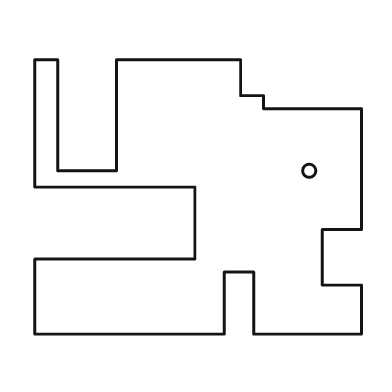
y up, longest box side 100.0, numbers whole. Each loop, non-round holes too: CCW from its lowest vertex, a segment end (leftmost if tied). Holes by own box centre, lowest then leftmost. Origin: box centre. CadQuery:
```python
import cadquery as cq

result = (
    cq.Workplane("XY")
    .moveTo(-50.0, -42.0)
    .lineTo(8.0, -42.0)
    .lineTo(8.0, -23.0)
    .lineTo(17.0, -23.0)
    .lineTo(17.0, -42.0)
    .lineTo(50.0, -42.0)
    .lineTo(50.0, -27.0)
    .lineTo(38.0, -27.0)
    .lineTo(38.0, -10.0)
    .lineTo(50.0, -10.0)
    .lineTo(50.0, 27.0)
    .lineTo(20.0, 27.0)
    .lineTo(20.0, 31.0)
    .lineTo(13.0, 31.0)
    .lineTo(13.0, 42.0)
    .lineTo(-25.0, 42.0)
    .lineTo(-25.0, 8.0)
    .lineTo(-43.0, 8.0)
    .lineTo(-43.0, 42.0)
    .lineTo(-50.0, 42.0)
    .lineTo(-50.0, 3.0)
    .lineTo(-1.0, 3.0)
    .lineTo(-1.0, -19.0)
    .lineTo(-50.0, -19.0)
    .close()
    .moveTo(34.0, 8.0)
    .circle(2.0)
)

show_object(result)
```